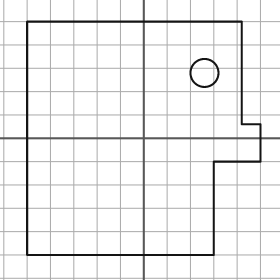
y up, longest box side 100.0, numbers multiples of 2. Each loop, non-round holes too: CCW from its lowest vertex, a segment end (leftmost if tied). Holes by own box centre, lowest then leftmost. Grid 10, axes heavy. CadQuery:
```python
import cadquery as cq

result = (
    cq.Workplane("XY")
    .moveTo(-50.0, -50.0)
    .lineTo(30.0, -50.0)
    .lineTo(30.0, -10.0)
    .lineTo(50.0, -10.0)
    .lineTo(50.0, 6.0)
    .lineTo(42.0, 6.0)
    .lineTo(42.0, 50.0)
    .lineTo(-50.0, 50.0)
    .close()
    .moveTo(26.0, 28.0)
    .circle(6.0)
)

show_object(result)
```